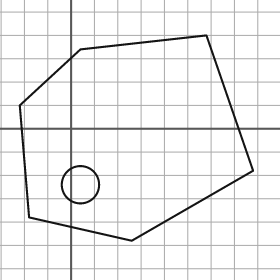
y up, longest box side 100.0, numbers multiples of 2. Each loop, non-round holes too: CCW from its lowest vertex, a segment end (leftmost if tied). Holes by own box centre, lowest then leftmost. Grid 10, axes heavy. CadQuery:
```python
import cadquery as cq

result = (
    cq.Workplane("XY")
    .moveTo(26.0, -48.0)
    .lineTo(78.0, -18.0)
    .lineTo(58.0, 40.0)
    .lineTo(4.0, 34.0)
    .lineTo(-22.0, 10.0)
    .lineTo(-18.0, -38.0)
    .close()
    .moveTo(4.0, -24.0)
    .circle(8.0)
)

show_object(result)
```